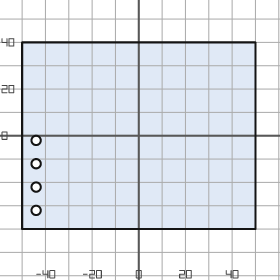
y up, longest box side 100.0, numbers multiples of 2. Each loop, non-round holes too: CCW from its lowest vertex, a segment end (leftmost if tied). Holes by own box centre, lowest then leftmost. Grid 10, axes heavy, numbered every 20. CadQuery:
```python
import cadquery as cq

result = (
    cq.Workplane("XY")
    .moveTo(-50.0, -40.0)
    .lineTo(50.0, -40.0)
    .lineTo(50.0, 40.0)
    .lineTo(-50.0, 40.0)
    .close()
    .moveTo(-44.0, -32.0)
    .circle(2.0)
    .moveTo(-44.0, -22.0)
    .circle(2.0)
    .moveTo(-44.0, -12.0)
    .circle(2.0)
    .moveTo(-44.0, -2.0)
    .circle(2.0)
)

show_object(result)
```